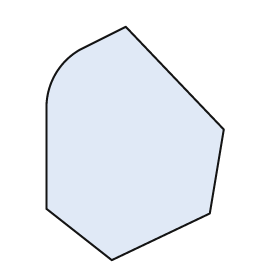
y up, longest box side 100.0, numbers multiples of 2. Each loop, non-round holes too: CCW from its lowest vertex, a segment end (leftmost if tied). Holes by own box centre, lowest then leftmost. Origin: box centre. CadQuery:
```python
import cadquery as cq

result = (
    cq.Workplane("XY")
    .moveTo(-10.0, -50.0)
    .lineTo(32.0, -30.0)
    .lineTo(38.0, 6.0)
    .lineTo(-4.0, 50.0)
    .lineTo(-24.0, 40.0)
    .threePointArc((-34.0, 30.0), (-38.0, 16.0))
    .lineTo(-38.0, -28.0)
    .close()
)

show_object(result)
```